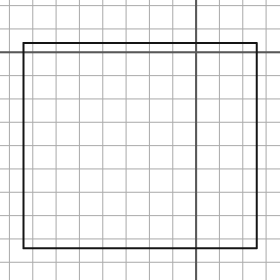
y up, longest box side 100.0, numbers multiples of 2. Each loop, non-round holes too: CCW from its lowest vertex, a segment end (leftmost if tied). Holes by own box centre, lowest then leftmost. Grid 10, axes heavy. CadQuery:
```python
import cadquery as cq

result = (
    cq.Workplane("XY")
    .moveTo(-74.0, -84.0)
    .lineTo(26.0, -84.0)
    .lineTo(26.0, 4.0)
    .lineTo(-74.0, 4.0)
    .close()
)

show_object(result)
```